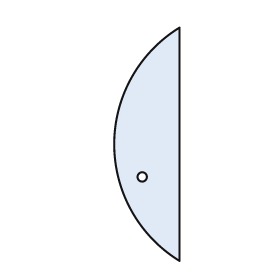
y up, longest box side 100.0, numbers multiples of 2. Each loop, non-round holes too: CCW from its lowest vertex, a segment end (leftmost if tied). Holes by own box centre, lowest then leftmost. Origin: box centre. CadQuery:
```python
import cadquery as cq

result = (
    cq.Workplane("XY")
    .moveTo(14.0, -50.0)
    .lineTo(14.0, 50.0)
    .threePointArc((-14.0, 0.0), (14.0, -50.0))
    .close()
    .moveTo(-2.0, -14.0)
    .circle(2.0)
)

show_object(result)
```